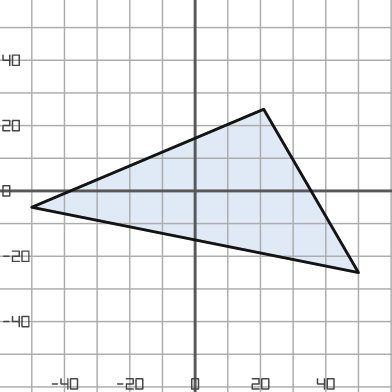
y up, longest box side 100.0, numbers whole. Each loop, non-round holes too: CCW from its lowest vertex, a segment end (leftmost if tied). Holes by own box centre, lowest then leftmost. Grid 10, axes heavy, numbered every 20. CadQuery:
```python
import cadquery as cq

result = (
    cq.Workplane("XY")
    .moveTo(50.0, -25.0)
    .lineTo(21.0, 25.0)
    .lineTo(-50.0, -5.0)
    .close()
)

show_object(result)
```